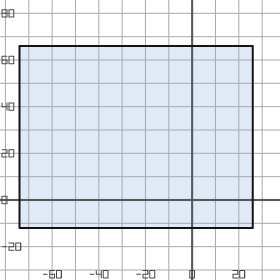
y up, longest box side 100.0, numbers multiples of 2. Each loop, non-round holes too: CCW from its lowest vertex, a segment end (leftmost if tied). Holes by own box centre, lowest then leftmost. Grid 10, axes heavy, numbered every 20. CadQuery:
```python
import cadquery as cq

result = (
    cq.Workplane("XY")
    .moveTo(-74.0, -12.0)
    .lineTo(26.0, -12.0)
    .lineTo(26.0, 66.0)
    .lineTo(-74.0, 66.0)
    .close()
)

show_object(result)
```